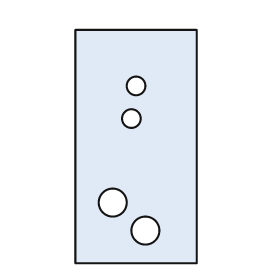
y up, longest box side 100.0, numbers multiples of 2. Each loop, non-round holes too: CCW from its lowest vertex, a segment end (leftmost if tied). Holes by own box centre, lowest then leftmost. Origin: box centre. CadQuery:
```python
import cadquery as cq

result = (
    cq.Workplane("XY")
    .moveTo(-26.0, -50.0)
    .lineTo(26.0, -50.0)
    .lineTo(26.0, 50.0)
    .lineTo(-26.0, 50.0)
    .close()
    .moveTo(4.0, -36.0)
    .circle(6.0)
    .moveTo(-10.0, -24.0)
    .circle(6.0)
    .moveTo(-2.0, 12.0)
    .circle(4.0)
    .moveTo(0.0, 26.0)
    .circle(4.0)
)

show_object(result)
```